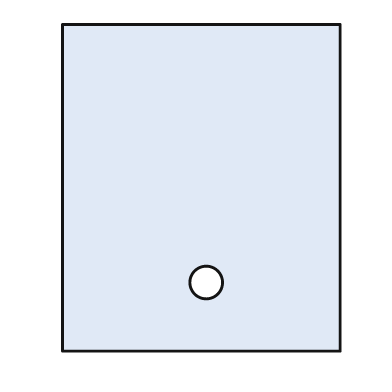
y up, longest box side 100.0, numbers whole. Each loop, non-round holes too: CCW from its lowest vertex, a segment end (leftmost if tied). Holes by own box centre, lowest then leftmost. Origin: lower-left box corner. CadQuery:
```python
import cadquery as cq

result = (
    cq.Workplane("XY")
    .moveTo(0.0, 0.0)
    .lineTo(85.0, 0.0)
    .lineTo(85.0, 100.0)
    .lineTo(0.0, 100.0)
    .close()
    .moveTo(44.0, 21.0)
    .circle(5.0)
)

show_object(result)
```